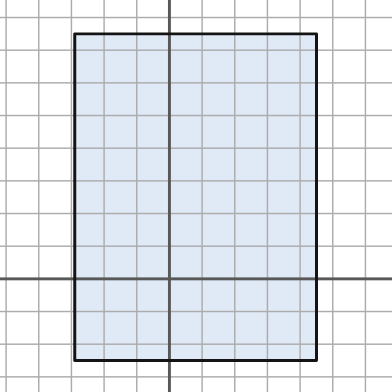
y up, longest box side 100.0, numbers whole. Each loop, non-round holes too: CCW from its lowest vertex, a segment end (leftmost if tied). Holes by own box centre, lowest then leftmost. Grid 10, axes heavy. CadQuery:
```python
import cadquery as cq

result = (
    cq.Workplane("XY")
    .moveTo(-29.0, -25.0)
    .lineTo(45.0, -25.0)
    .lineTo(45.0, 75.0)
    .lineTo(-29.0, 75.0)
    .close()
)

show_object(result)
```